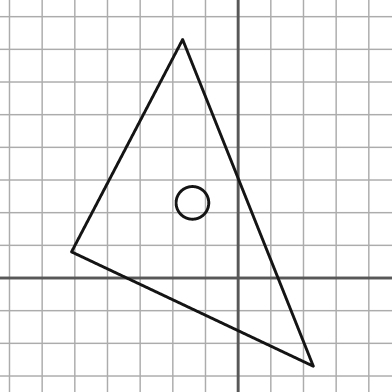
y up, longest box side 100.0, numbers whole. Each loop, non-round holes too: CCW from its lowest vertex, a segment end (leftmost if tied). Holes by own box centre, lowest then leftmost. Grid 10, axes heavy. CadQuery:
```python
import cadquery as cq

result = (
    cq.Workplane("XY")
    .moveTo(23.0, -27.0)
    .lineTo(-17.0, 73.0)
    .lineTo(-51.0, 8.0)
    .close()
    .moveTo(-14.0, 23.0)
    .circle(5.0)
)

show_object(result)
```